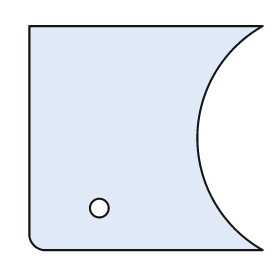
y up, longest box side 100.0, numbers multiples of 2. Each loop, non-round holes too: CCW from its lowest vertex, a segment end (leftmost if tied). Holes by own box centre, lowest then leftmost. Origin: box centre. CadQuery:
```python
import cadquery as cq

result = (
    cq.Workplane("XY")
    .moveTo(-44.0, -48.0)
    .lineTo(50.0, -48.0)
    .threePointArc((22.0, 0.0), (50.0, 48.0))
    .lineTo(-50.0, 48.0)
    .lineTo(-50.0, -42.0)
    .threePointArc((-48.0, -46.0), (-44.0, -48.0))
    .close()
    .moveTo(-20.0, -30.0)
    .circle(4.0)
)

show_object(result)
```